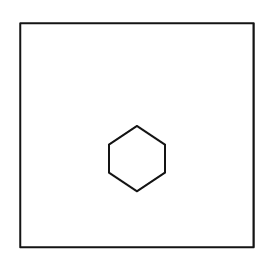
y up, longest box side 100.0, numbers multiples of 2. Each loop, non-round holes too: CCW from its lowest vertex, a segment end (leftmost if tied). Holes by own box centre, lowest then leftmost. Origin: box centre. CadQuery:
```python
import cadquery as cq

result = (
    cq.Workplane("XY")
    .moveTo(-50.0, -48.0)
    .lineTo(50.0, -48.0)
    .lineTo(50.0, 48.0)
    .lineTo(-50.0, 48.0)
    .close()
    .moveTo(0.0, -24.0)
    .lineTo(12.0, -16.0)
    .lineTo(12.0, -4.0)
    .lineTo(0.0, 4.0)
    .lineTo(-12.0, -4.0)
    .lineTo(-12.0, -16.0)
    .close()
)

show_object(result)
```